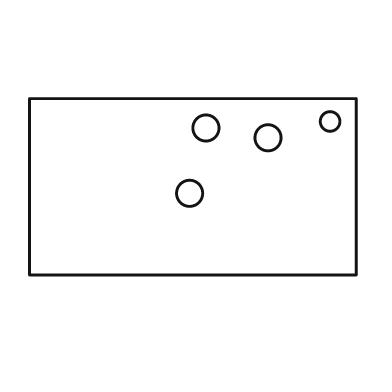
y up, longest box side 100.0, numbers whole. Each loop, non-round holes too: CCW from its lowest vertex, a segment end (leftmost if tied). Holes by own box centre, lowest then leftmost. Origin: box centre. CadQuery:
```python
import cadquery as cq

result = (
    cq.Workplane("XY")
    .moveTo(-50.0, -27.0)
    .lineTo(50.0, -27.0)
    .lineTo(50.0, 27.0)
    .lineTo(-50.0, 27.0)
    .close()
    .moveTo(-1.0, -2.0)
    .circle(4.0)
    .moveTo(23.0, 15.0)
    .circle(4.0)
    .moveTo(4.0, 18.0)
    .circle(4.0)
    .moveTo(42.0, 20.0)
    .circle(3.0)
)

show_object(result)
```